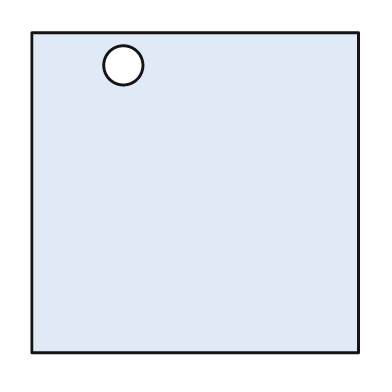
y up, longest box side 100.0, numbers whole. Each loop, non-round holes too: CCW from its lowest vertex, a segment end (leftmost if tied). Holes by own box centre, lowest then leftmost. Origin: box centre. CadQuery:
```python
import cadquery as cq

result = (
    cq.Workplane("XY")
    .moveTo(-50.0, -49.0)
    .lineTo(50.0, -49.0)
    .lineTo(50.0, 49.0)
    .lineTo(-50.0, 49.0)
    .close()
    .moveTo(-22.0, 39.0)
    .circle(6.0)
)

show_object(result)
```